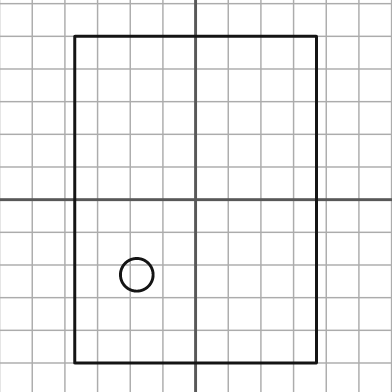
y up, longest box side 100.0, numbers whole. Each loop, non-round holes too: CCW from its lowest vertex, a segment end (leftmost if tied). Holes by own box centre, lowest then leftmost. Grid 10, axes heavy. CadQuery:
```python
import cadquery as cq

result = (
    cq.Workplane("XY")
    .moveTo(-37.0, -50.0)
    .lineTo(37.0, -50.0)
    .lineTo(37.0, 50.0)
    .lineTo(-37.0, 50.0)
    .close()
    .moveTo(-18.0, -23.0)
    .circle(5.0)
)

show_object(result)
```